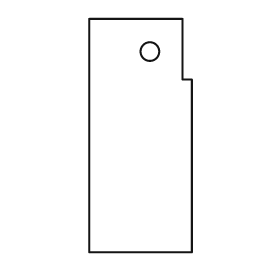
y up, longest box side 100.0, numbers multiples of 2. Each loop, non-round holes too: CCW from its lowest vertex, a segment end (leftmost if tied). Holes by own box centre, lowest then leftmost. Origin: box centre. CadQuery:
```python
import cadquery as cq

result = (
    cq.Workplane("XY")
    .moveTo(-22.0, -50.0)
    .lineTo(22.0, -50.0)
    .lineTo(22.0, 24.0)
    .lineTo(18.0, 24.0)
    .lineTo(18.0, 50.0)
    .lineTo(-22.0, 50.0)
    .close()
    .moveTo(4.0, 36.0)
    .circle(4.0)
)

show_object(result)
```